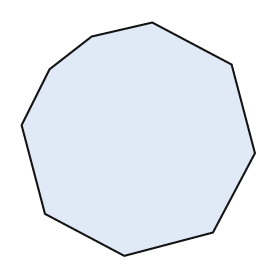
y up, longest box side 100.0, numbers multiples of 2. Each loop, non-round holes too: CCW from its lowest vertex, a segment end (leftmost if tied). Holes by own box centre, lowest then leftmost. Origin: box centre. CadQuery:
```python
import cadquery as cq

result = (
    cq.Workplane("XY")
    .moveTo(-6.0, -50.0)
    .lineTo(32.0, -40.0)
    .lineTo(50.0, -6.0)
    .lineTo(40.0, 32.0)
    .lineTo(6.0, 50.0)
    .lineTo(-20.0, 44.0)
    .lineTo(-38.0, 30.0)
    .lineTo(-50.0, 6.0)
    .lineTo(-40.0, -32.0)
    .close()
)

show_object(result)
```